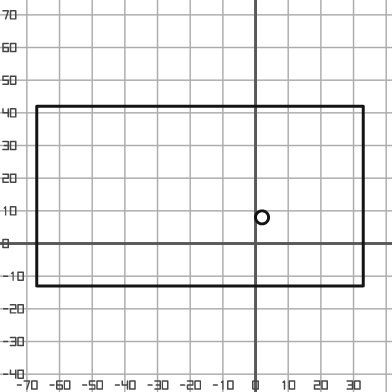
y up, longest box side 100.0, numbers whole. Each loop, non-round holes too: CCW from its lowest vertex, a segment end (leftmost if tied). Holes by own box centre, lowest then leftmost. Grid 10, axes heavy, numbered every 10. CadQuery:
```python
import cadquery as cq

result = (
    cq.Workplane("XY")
    .moveTo(-67.0, -13.0)
    .lineTo(33.0, -13.0)
    .lineTo(33.0, 42.0)
    .lineTo(-67.0, 42.0)
    .close()
    .moveTo(2.0, 8.0)
    .circle(2.0)
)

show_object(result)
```